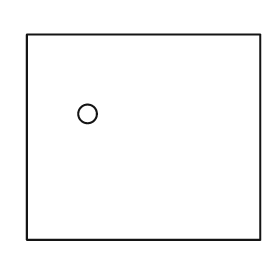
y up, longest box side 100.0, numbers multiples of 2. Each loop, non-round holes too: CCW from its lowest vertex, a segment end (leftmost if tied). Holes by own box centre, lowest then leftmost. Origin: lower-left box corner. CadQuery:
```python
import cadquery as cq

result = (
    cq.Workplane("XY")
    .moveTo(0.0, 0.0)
    .lineTo(100.0, 0.0)
    .lineTo(100.0, 88.0)
    .lineTo(0.0, 88.0)
    .close()
    .moveTo(26.0, 54.0)
    .circle(4.0)
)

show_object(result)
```